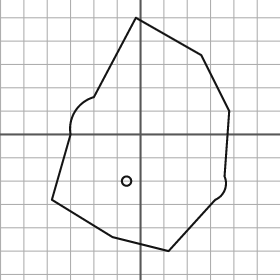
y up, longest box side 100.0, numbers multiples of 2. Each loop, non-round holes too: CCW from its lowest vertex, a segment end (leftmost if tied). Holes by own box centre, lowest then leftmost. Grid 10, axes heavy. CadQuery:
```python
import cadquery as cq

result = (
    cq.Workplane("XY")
    .moveTo(12.0, -50.0)
    .lineTo(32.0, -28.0)
    .threePointArc((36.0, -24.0), (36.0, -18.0))
    .lineTo(38.0, 10.0)
    .lineTo(26.0, 34.0)
    .lineTo(-2.0, 50.0)
    .lineTo(-20.0, 16.0)
    .threePointArc((-28.0, 10.0), (-30.0, 0.0))
    .lineTo(-38.0, -28.0)
    .lineTo(-12.0, -44.0)
    .close()
    .moveTo(-6.0, -20.0)
    .circle(2.0)
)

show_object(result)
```